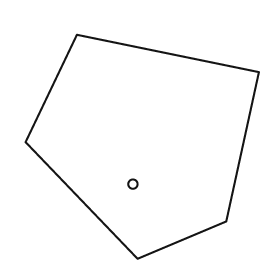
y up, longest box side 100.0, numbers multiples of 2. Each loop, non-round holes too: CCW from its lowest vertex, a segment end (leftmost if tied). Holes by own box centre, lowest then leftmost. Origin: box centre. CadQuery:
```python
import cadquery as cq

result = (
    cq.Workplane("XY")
    .moveTo(-2.0, -48.0)
    .lineTo(36.0, -32.0)
    .lineTo(50.0, 32.0)
    .lineTo(-28.0, 48.0)
    .lineTo(-50.0, 2.0)
    .close()
    .moveTo(-4.0, -16.0)
    .circle(2.0)
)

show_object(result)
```